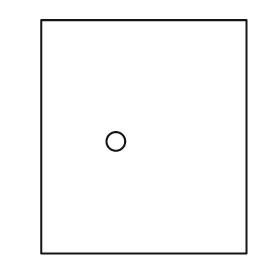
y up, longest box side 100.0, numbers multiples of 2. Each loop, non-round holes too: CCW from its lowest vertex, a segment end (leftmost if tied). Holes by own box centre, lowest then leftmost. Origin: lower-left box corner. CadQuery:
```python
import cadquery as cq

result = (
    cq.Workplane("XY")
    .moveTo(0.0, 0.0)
    .lineTo(88.0, 0.0)
    .lineTo(88.0, 100.0)
    .lineTo(0.0, 100.0)
    .close()
    .moveTo(32.0, 48.0)
    .circle(4.0)
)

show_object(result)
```